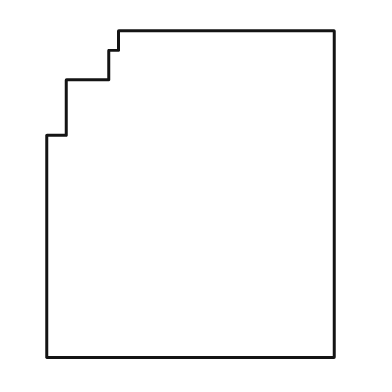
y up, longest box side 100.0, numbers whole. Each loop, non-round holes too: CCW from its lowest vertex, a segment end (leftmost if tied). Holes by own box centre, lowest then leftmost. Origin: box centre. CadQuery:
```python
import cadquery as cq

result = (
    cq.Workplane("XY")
    .moveTo(-44.0, -50.0)
    .lineTo(44.0, -50.0)
    .lineTo(44.0, 50.0)
    .lineTo(-22.0, 50.0)
    .lineTo(-22.0, 44.0)
    .lineTo(-25.0, 44.0)
    .lineTo(-25.0, 35.0)
    .lineTo(-38.0, 35.0)
    .lineTo(-38.0, 18.0)
    .lineTo(-44.0, 18.0)
    .close()
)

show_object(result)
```